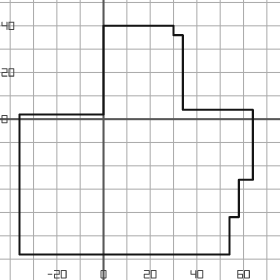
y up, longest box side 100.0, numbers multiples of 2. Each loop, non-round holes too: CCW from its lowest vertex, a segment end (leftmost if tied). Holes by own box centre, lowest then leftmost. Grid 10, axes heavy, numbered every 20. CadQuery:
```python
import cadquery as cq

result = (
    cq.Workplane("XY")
    .moveTo(-36.0, -58.0)
    .lineTo(54.0, -58.0)
    .lineTo(54.0, -42.0)
    .lineTo(58.0, -42.0)
    .lineTo(58.0, -26.0)
    .lineTo(64.0, -26.0)
    .lineTo(64.0, 4.0)
    .lineTo(34.0, 4.0)
    .lineTo(34.0, 36.0)
    .lineTo(30.0, 36.0)
    .lineTo(30.0, 40.0)
    .lineTo(0.0, 40.0)
    .lineTo(0.0, 2.0)
    .lineTo(-36.0, 2.0)
    .close()
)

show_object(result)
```